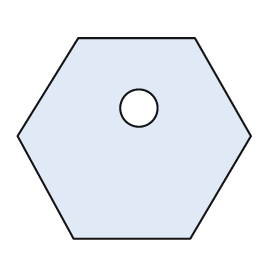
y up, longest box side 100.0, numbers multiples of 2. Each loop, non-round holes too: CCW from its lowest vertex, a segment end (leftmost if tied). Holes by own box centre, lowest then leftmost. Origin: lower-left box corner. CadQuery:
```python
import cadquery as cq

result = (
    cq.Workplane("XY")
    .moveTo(24.0, 0.0)
    .lineTo(74.0, 0.0)
    .lineTo(100.0, 44.0)
    .lineTo(76.0, 86.0)
    .lineTo(26.0, 86.0)
    .lineTo(0.0, 44.0)
    .close()
    .moveTo(52.0, 56.0)
    .circle(8.0)
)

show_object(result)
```